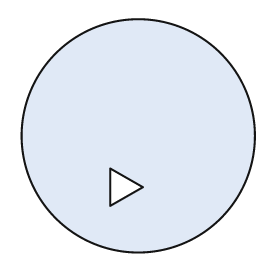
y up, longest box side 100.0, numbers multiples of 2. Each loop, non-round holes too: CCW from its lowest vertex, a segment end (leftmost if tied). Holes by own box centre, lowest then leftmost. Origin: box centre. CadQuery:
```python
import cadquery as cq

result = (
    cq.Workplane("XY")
    .moveTo(0.0, 0.0)
    .circle(50.0)
    .moveTo(-12.0, -30.0)
    .lineTo(2.0, -22.0)
    .lineTo(-12.0, -14.0)
    .close()
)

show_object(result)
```